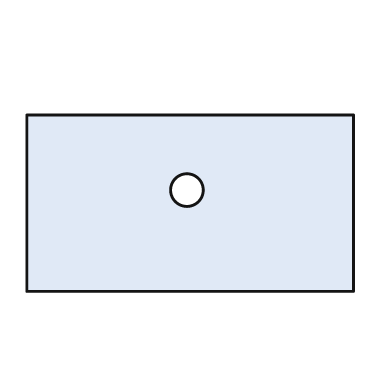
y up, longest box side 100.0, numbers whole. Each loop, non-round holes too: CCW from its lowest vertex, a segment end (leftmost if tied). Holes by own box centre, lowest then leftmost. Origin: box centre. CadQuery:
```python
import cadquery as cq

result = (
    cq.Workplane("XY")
    .moveTo(-50.0, -27.0)
    .lineTo(50.0, -27.0)
    .lineTo(50.0, 27.0)
    .lineTo(-50.0, 27.0)
    .close()
    .moveTo(-1.0, 4.0)
    .circle(5.0)
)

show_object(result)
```